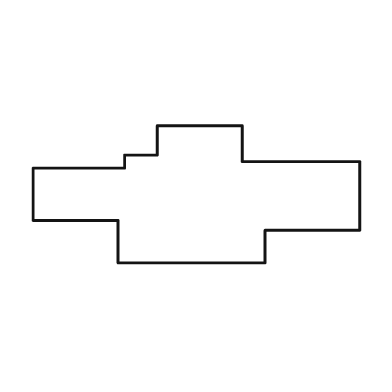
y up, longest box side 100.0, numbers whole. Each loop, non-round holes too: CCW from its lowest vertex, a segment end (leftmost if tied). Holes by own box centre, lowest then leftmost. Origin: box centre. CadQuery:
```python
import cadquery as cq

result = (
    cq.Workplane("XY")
    .moveTo(-24.0, -21.0)
    .lineTo(21.0, -21.0)
    .lineTo(21.0, -11.0)
    .lineTo(50.0, -11.0)
    .lineTo(50.0, 10.0)
    .lineTo(14.0, 10.0)
    .lineTo(14.0, 21.0)
    .lineTo(-12.0, 21.0)
    .lineTo(-12.0, 12.0)
    .lineTo(-22.0, 12.0)
    .lineTo(-22.0, 8.0)
    .lineTo(-50.0, 8.0)
    .lineTo(-50.0, -8.0)
    .lineTo(-24.0, -8.0)
    .close()
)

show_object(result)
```